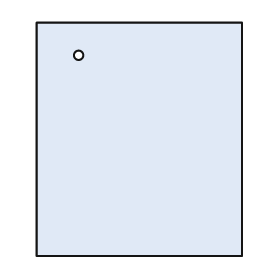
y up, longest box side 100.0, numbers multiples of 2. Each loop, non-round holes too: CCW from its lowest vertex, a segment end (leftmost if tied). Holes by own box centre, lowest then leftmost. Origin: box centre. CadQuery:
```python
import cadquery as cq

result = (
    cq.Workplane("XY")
    .moveTo(-44.0, -50.0)
    .lineTo(44.0, -50.0)
    .lineTo(44.0, 50.0)
    .lineTo(-44.0, 50.0)
    .close()
    .moveTo(-26.0, 36.0)
    .circle(2.0)
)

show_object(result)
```